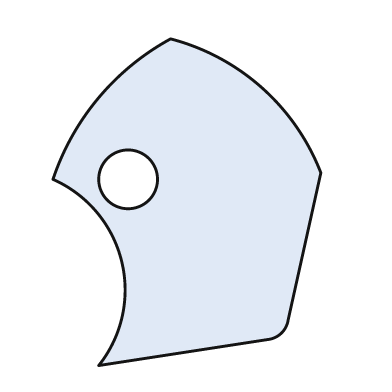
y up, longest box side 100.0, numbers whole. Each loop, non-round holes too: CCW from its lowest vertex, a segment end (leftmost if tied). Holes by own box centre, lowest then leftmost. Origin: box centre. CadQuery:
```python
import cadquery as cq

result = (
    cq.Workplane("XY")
    .moveTo(-27.0, -50.0)
    .lineTo(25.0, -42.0)
    .threePointArc((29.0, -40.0), (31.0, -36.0))
    .lineTo(41.0, 9.0)
    .threePointArc((23.0, 35.0), (-5.0, 50.0))
    .threePointArc((-27.0, 32.0), (-41.0, 7.0))
    .threePointArc((-20.0, -18.0), (-27.0, -50.0))
    .close()
    .moveTo(-18.0, 7.0)
    .circle(9.0)
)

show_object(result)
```